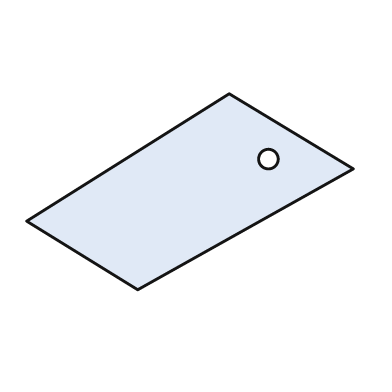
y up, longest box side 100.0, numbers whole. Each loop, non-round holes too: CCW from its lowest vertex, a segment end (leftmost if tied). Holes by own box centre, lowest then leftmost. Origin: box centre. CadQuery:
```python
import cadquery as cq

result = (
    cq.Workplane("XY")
    .moveTo(-16.0, -30.0)
    .lineTo(50.0, 7.0)
    .lineTo(12.0, 30.0)
    .lineTo(-50.0, -9.0)
    .close()
    .moveTo(24.0, 10.0)
    .circle(3.0)
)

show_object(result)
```